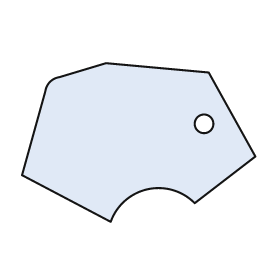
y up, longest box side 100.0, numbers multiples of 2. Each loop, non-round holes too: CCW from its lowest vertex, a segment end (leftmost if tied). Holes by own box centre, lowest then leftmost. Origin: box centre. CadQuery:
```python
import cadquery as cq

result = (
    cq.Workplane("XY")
    .moveTo(-12.0, -34.0)
    .threePointArc((4.0, -20.0), (24.0, -26.0))
    .lineTo(50.0, -6.0)
    .lineTo(30.0, 30.0)
    .lineTo(-14.0, 34.0)
    .lineTo(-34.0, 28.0)
    .threePointArc((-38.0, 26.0), (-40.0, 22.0))
    .lineTo(-50.0, -14.0)
    .close()
    .moveTo(28.0, 8.0)
    .circle(4.0)
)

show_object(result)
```